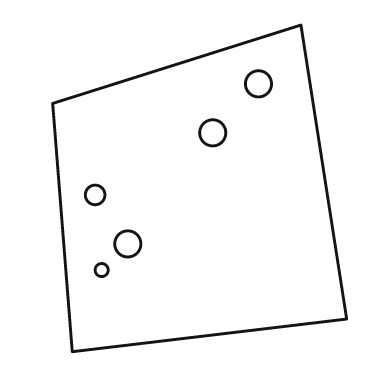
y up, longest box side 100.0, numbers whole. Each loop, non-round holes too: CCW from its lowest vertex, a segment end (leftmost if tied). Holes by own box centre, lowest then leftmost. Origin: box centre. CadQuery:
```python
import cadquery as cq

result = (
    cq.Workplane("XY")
    .moveTo(-39.0, -50.0)
    .lineTo(45.0, -40.0)
    .lineTo(31.0, 50.0)
    .lineTo(-45.0, 26.0)
    .close()
    .moveTo(-30.0, -25.0)
    .circle(2.0)
    .moveTo(-22.0, -17.0)
    .circle(4.0)
    .moveTo(-32.0, -2.0)
    .circle(3.0)
    .moveTo(4.0, 17.0)
    .circle(4.0)
    .moveTo(18.0, 32.0)
    .circle(4.0)
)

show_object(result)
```